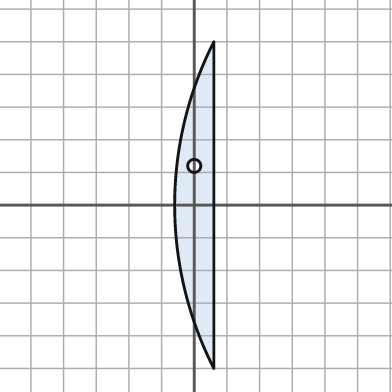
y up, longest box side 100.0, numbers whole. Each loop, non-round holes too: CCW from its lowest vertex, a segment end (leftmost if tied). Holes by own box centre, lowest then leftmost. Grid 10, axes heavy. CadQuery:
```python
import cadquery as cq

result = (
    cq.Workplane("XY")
    .moveTo(6.0, -50.0)
    .lineTo(6.0, 50.0)
    .threePointArc((-6.0, 0.0), (6.0, -50.0))
    .close()
    .moveTo(0.0, 12.0)
    .circle(2.0)
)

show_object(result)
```